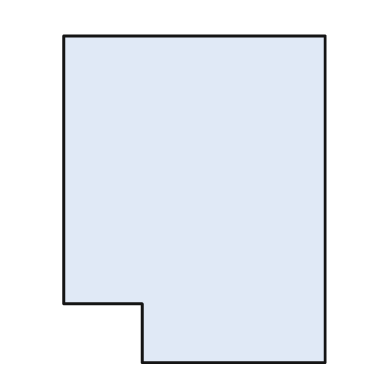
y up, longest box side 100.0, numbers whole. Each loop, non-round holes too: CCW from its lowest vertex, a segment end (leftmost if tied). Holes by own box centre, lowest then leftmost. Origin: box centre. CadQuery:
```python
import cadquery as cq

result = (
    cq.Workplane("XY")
    .moveTo(-16.0, -50.0)
    .lineTo(40.0, -50.0)
    .lineTo(40.0, 50.0)
    .lineTo(-40.0, 50.0)
    .lineTo(-40.0, -32.0)
    .lineTo(-16.0, -32.0)
    .close()
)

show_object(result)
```